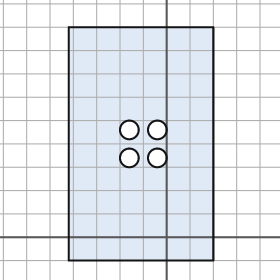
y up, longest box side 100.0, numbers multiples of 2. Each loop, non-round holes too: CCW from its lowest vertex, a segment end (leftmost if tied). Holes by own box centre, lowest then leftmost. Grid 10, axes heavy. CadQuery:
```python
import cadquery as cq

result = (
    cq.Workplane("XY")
    .moveTo(-42.0, -10.0)
    .lineTo(20.0, -10.0)
    .lineTo(20.0, 90.0)
    .lineTo(-42.0, 90.0)
    .close()
    .moveTo(-16.0, 34.0)
    .circle(4.0)
    .moveTo(-4.0, 34.0)
    .circle(4.0)
    .moveTo(-16.0, 46.0)
    .circle(4.0)
    .moveTo(-4.0, 46.0)
    .circle(4.0)
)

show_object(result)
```